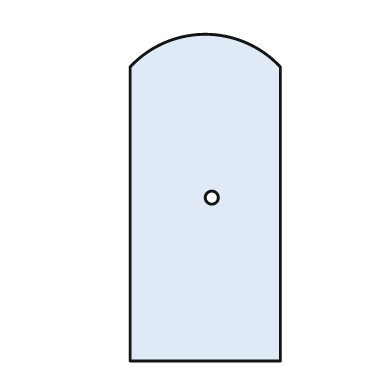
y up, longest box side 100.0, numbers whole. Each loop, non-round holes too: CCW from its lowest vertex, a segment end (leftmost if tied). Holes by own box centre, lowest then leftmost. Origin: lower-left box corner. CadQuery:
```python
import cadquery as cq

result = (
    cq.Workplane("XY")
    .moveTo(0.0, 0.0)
    .lineTo(46.0, 0.0)
    .lineTo(46.0, 90.0)
    .threePointArc((23.0, 100.0), (0.0, 90.0))
    .close()
    .moveTo(25.0, 50.0)
    .circle(2.0)
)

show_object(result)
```